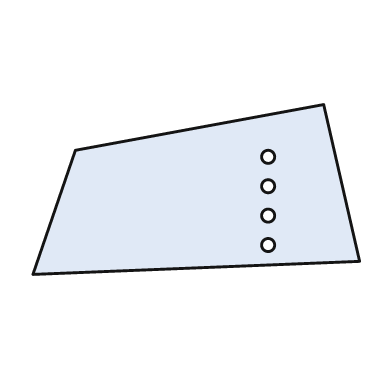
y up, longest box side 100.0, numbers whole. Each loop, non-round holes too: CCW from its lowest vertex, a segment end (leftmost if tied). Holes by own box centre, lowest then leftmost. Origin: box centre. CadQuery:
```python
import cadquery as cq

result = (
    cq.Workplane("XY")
    .moveTo(-50.0, -26.0)
    .lineTo(50.0, -22.0)
    .lineTo(39.0, 26.0)
    .lineTo(-37.0, 12.0)
    .close()
    .moveTo(22.0, -17.0)
    .circle(2.0)
    .moveTo(22.0, -8.0)
    .circle(2.0)
    .moveTo(22.0, 1.0)
    .circle(2.0)
    .moveTo(22.0, 10.0)
    .circle(2.0)
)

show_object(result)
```